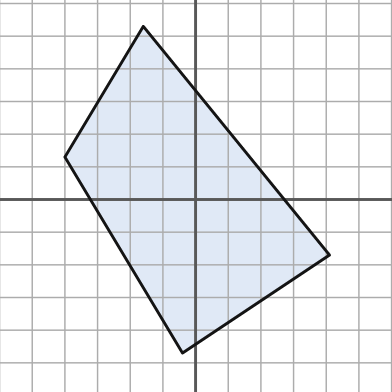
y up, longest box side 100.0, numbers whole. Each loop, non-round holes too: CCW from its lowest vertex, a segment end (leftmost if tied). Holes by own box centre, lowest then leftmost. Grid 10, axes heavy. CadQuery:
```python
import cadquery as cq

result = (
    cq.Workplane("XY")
    .moveTo(-4.0, -47.0)
    .lineTo(41.0, -17.0)
    .lineTo(-16.0, 53.0)
    .lineTo(-40.0, 13.0)
    .close()
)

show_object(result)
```